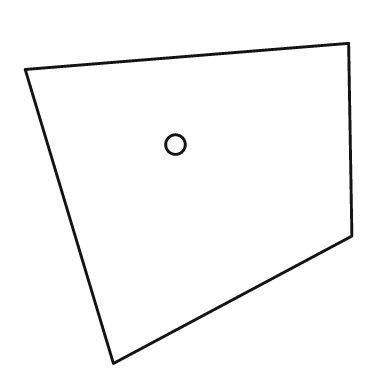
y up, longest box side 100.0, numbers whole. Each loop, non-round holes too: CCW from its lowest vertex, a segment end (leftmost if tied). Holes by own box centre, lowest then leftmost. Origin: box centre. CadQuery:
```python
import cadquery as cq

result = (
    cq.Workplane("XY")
    .moveTo(-23.0, -49.0)
    .lineTo(50.0, -10.0)
    .lineTo(49.0, 49.0)
    .lineTo(-50.0, 41.0)
    .close()
    .moveTo(-4.0, 18.0)
    .circle(3.0)
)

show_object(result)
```